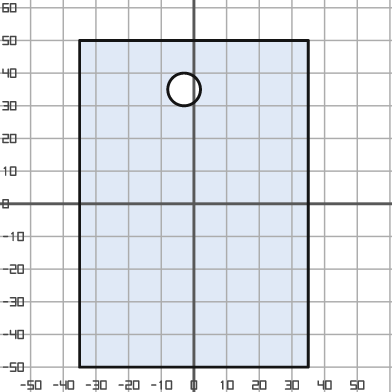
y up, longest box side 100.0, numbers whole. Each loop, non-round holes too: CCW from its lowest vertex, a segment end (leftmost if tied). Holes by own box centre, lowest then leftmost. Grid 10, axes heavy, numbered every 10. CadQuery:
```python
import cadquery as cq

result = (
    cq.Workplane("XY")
    .moveTo(-35.0, -50.0)
    .lineTo(35.0, -50.0)
    .lineTo(35.0, 50.0)
    .lineTo(-35.0, 50.0)
    .close()
    .moveTo(-3.0, 35.0)
    .circle(5.0)
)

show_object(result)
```